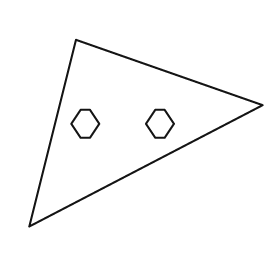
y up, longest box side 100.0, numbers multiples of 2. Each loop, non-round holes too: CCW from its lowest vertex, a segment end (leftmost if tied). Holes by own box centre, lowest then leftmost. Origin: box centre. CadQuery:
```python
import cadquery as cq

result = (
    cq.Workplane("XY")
    .moveTo(-50.0, -40.0)
    .lineTo(50.0, 12.0)
    .lineTo(-30.0, 40.0)
    .close()
    .moveTo(-28.0, -2.0)
    .lineTo(-24.0, -2.0)
    .lineTo(-20.0, 4.0)
    .lineTo(-24.0, 10.0)
    .lineTo(-28.0, 10.0)
    .lineTo(-32.0, 4.0)
    .close()
    .moveTo(4.0, -2.0)
    .lineTo(8.0, -2.0)
    .lineTo(12.0, 4.0)
    .lineTo(8.0, 10.0)
    .lineTo(4.0, 10.0)
    .lineTo(0.0, 4.0)
    .close()
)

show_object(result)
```